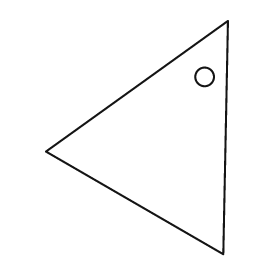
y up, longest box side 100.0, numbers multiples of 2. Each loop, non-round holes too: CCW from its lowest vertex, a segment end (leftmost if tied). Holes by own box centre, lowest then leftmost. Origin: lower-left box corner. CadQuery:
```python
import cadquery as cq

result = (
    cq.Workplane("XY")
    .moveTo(76.0, 0.0)
    .lineTo(78.0, 100.0)
    .lineTo(0.0, 44.0)
    .close()
    .moveTo(68.0, 76.0)
    .circle(4.0)
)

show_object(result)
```